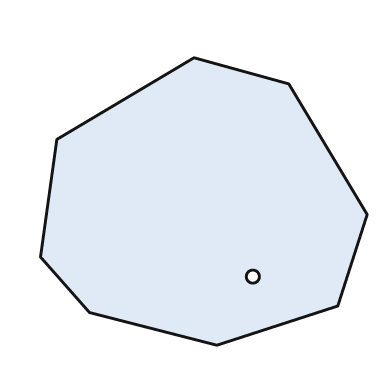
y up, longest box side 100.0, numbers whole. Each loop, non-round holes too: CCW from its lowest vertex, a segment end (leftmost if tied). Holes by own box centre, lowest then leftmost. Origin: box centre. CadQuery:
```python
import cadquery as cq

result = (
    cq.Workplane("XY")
    .moveTo(4.0, -44.0)
    .lineTo(41.0, -32.0)
    .lineTo(50.0, -4.0)
    .lineTo(26.0, 36.0)
    .lineTo(-3.0, 44.0)
    .lineTo(-45.0, 19.0)
    .lineTo(-50.0, -17.0)
    .lineTo(-35.0, -34.0)
    .close()
    .moveTo(15.0, -23.0)
    .circle(2.0)
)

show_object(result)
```